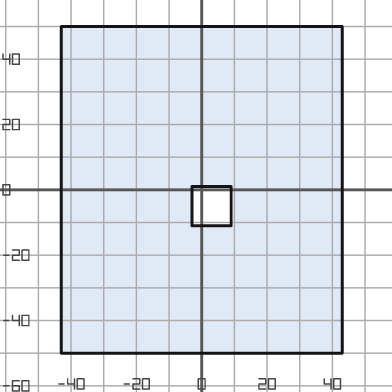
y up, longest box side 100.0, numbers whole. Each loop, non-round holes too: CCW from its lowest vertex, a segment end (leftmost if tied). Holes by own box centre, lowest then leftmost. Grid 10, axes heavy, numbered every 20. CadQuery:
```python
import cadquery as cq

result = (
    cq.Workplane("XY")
    .moveTo(-43.0, -50.0)
    .lineTo(43.0, -50.0)
    .lineTo(43.0, 50.0)
    .lineTo(-43.0, 50.0)
    .close()
    .moveTo(-3.0, -11.0)
    .lineTo(9.0, -11.0)
    .lineTo(9.0, 1.0)
    .lineTo(-3.0, 1.0)
    .close()
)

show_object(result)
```